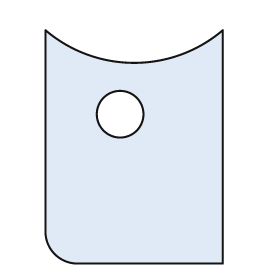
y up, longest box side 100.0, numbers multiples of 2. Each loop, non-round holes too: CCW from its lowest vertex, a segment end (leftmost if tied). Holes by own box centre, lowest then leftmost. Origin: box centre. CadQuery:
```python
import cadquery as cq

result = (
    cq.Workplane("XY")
    .moveTo(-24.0, -50.0)
    .lineTo(38.0, -50.0)
    .lineTo(38.0, 50.0)
    .threePointArc((0.0, 36.0), (-38.0, 50.0))
    .lineTo(-38.0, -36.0)
    .threePointArc((-34.0, -46.0), (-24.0, -50.0))
    .close()
    .moveTo(-6.0, 14.0)
    .circle(10.0)
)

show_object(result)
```